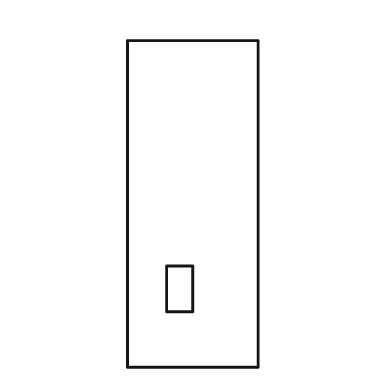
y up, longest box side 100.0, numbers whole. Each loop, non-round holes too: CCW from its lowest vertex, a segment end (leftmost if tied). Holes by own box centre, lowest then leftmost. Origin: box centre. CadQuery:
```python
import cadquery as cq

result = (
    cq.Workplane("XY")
    .moveTo(-20.0, -50.0)
    .lineTo(20.0, -50.0)
    .lineTo(20.0, 50.0)
    .lineTo(-20.0, 50.0)
    .close()
    .moveTo(-8.0, -33.0)
    .lineTo(0.0, -33.0)
    .lineTo(0.0, -19.0)
    .lineTo(-8.0, -19.0)
    .close()
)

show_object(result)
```